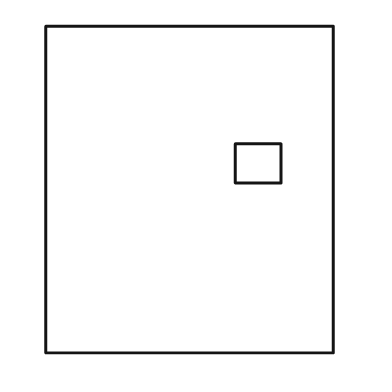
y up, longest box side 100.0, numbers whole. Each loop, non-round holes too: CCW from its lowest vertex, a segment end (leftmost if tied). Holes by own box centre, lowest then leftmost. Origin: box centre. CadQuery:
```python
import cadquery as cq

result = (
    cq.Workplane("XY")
    .moveTo(-44.0, -50.0)
    .lineTo(44.0, -50.0)
    .lineTo(44.0, 50.0)
    .lineTo(-44.0, 50.0)
    .close()
    .moveTo(14.0, 2.0)
    .lineTo(28.0, 2.0)
    .lineTo(28.0, 14.0)
    .lineTo(14.0, 14.0)
    .close()
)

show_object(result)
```